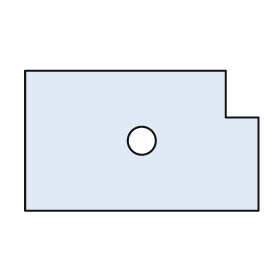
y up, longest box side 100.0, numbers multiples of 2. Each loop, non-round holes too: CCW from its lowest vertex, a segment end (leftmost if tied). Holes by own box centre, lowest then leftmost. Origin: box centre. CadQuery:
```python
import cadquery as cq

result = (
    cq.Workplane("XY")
    .moveTo(-50.0, -30.0)
    .lineTo(50.0, -30.0)
    .lineTo(50.0, 10.0)
    .lineTo(36.0, 10.0)
    .lineTo(36.0, 30.0)
    .lineTo(-50.0, 30.0)
    .close()
    .moveTo(0.0, 0.0)
    .circle(6.0)
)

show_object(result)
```